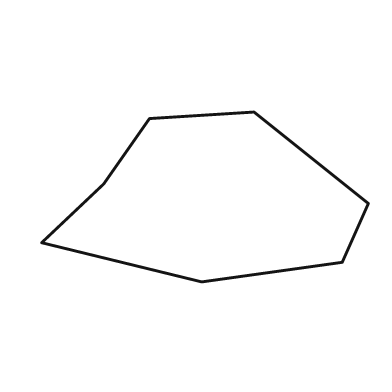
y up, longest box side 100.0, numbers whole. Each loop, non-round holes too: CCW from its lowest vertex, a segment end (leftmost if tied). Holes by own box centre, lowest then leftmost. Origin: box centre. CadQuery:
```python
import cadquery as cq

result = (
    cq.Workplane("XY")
    .moveTo(-1.0, -26.0)
    .lineTo(42.0, -20.0)
    .lineTo(50.0, -2.0)
    .lineTo(15.0, 26.0)
    .lineTo(-17.0, 24.0)
    .lineTo(-31.0, 4.0)
    .lineTo(-50.0, -14.0)
    .close()
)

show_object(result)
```